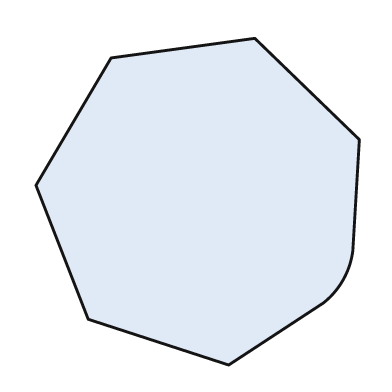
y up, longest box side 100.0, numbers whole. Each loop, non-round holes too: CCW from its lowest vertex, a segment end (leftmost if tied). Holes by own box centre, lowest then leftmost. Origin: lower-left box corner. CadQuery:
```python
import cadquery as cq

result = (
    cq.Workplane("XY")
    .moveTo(59.0, 0.0)
    .lineTo(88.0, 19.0)
    .threePointArc((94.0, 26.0), (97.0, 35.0))
    .lineTo(99.0, 69.0)
    .lineTo(67.0, 100.0)
    .lineTo(23.0, 94.0)
    .lineTo(0.0, 55.0)
    .lineTo(16.0, 14.0)
    .close()
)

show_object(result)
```